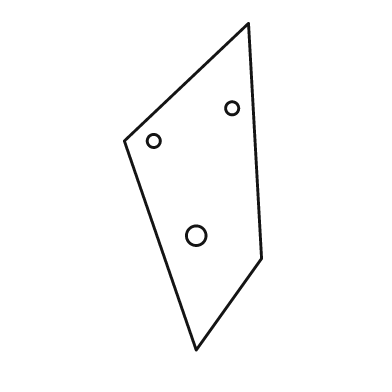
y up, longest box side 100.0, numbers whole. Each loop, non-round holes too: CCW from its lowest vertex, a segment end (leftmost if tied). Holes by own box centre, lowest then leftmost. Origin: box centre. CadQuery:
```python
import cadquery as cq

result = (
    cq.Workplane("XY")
    .moveTo(1.0, -50.0)
    .lineTo(21.0, -22.0)
    .lineTo(17.0, 50.0)
    .lineTo(-21.0, 14.0)
    .close()
    .moveTo(1.0, -15.0)
    .circle(3.0)
    .moveTo(-12.0, 14.0)
    .circle(2.0)
    .moveTo(12.0, 24.0)
    .circle(2.0)
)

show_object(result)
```